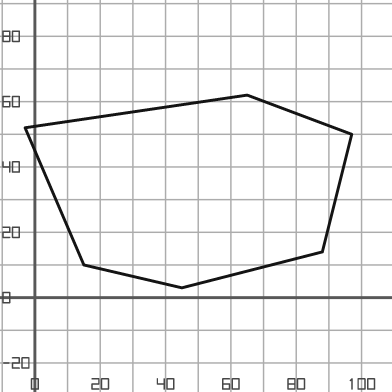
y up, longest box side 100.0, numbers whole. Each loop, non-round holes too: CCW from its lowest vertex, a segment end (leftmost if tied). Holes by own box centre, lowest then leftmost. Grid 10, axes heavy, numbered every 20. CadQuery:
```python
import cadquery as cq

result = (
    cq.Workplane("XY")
    .moveTo(45.0, 3.0)
    .lineTo(88.0, 14.0)
    .lineTo(97.0, 50.0)
    .lineTo(65.0, 62.0)
    .lineTo(-3.0, 52.0)
    .lineTo(15.0, 10.0)
    .close()
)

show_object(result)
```